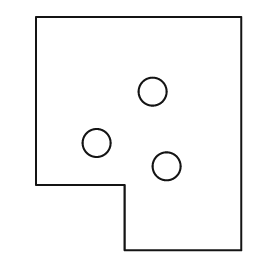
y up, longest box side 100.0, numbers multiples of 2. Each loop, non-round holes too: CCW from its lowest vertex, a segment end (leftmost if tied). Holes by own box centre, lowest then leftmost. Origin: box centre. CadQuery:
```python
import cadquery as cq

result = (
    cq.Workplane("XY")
    .moveTo(-6.0, -50.0)
    .lineTo(44.0, -50.0)
    .lineTo(44.0, 50.0)
    .lineTo(-44.0, 50.0)
    .lineTo(-44.0, -22.0)
    .lineTo(-6.0, -22.0)
    .close()
    .moveTo(12.0, -14.0)
    .circle(6.0)
    .moveTo(-18.0, -4.0)
    .circle(6.0)
    .moveTo(6.0, 18.0)
    .circle(6.0)
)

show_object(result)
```